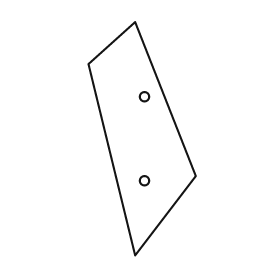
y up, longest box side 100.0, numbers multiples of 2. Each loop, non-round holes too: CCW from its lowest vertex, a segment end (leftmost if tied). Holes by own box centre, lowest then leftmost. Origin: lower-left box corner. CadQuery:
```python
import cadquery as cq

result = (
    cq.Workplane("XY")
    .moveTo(20.0, 0.0)
    .lineTo(46.0, 34.0)
    .lineTo(20.0, 100.0)
    .lineTo(0.0, 82.0)
    .close()
    .moveTo(24.0, 32.0)
    .circle(2.0)
    .moveTo(24.0, 68.0)
    .circle(2.0)
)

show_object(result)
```